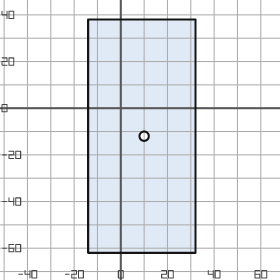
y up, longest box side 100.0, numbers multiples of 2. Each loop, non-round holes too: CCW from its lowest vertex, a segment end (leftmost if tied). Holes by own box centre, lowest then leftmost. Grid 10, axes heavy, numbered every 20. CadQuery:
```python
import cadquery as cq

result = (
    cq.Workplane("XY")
    .moveTo(-14.0, -62.0)
    .lineTo(32.0, -62.0)
    .lineTo(32.0, 38.0)
    .lineTo(-14.0, 38.0)
    .close()
    .moveTo(10.0, -12.0)
    .circle(2.0)
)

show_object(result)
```